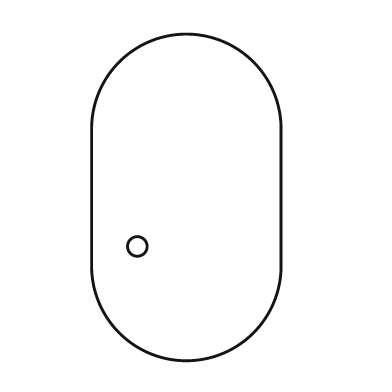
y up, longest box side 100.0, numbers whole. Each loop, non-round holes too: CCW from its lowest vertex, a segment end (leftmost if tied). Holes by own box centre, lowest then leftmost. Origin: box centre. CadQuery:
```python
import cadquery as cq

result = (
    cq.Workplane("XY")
    .moveTo(-29.0, -21.0)
    .threePointArc((0.0, -50.0), (29.0, -21.0))
    .lineTo(29.0, 21.0)
    .threePointArc((0.0, 50.0), (-29.0, 21.0))
    .close()
    .moveTo(-15.0, -15.0)
    .circle(3.0)
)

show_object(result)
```